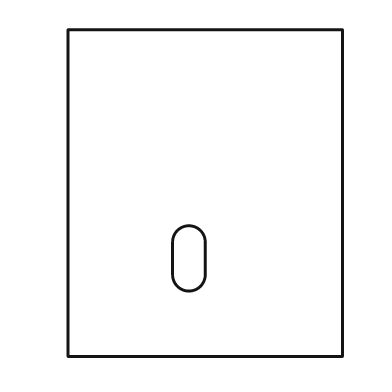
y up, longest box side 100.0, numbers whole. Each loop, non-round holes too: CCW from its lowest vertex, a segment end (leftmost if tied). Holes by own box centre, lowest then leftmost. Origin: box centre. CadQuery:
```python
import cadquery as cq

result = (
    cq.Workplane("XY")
    .moveTo(-42.0, -50.0)
    .lineTo(42.0, -50.0)
    .lineTo(42.0, 50.0)
    .lineTo(-42.0, 50.0)
    .close()
    .moveTo(-10.0, -25.0)
    .threePointArc((-5.0, -30.0), (0.0, -25.0))
    .lineTo(0.0, -15.0)
    .threePointArc((-5.0, -10.0), (-10.0, -15.0))
    .close()
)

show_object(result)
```